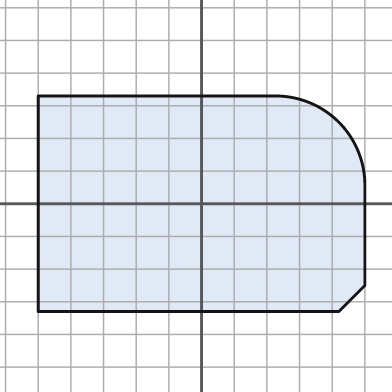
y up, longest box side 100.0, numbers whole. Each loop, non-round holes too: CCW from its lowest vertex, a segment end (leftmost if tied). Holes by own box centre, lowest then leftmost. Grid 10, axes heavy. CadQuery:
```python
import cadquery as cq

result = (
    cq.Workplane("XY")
    .moveTo(-50.0, -33.0)
    .lineTo(42.0, -33.0)
    .lineTo(50.0, -25.0)
    .lineTo(50.0, 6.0)
    .threePointArc((42.0, 25.0), (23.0, 33.0))
    .lineTo(-50.0, 33.0)
    .close()
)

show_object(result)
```